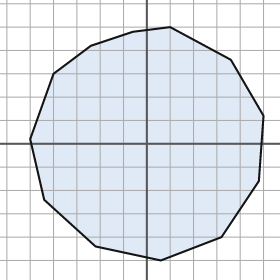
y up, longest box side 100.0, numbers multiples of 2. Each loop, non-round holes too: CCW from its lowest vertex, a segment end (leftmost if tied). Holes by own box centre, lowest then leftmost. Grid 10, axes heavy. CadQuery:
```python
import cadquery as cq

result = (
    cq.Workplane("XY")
    .moveTo(6.0, -50.0)
    .lineTo(32.0, -40.0)
    .lineTo(48.0, -16.0)
    .lineTo(50.0, 12.0)
    .lineTo(36.0, 36.0)
    .lineTo(10.0, 50.0)
    .lineTo(-6.0, 48.0)
    .lineTo(-24.0, 42.0)
    .lineTo(-40.0, 30.0)
    .lineTo(-50.0, 2.0)
    .lineTo(-44.0, -24.0)
    .lineTo(-22.0, -44.0)
    .close()
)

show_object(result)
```